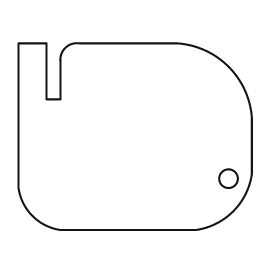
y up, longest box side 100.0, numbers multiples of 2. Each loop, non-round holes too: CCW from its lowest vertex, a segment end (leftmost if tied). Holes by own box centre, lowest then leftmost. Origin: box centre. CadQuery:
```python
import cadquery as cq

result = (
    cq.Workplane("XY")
    .moveTo(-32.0, -40.0)
    .lineTo(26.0, -40.0)
    .threePointArc((42.0, -32.0), (50.0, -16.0))
    .lineTo(50.0, 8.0)
    .threePointArc((40.0, 30.0), (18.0, 40.0))
    .lineTo(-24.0, 40.0)
    .threePointArc((-30.0, 38.0), (-32.0, 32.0))
    .lineTo(-32.0, 16.0)
    .lineTo(-38.0, 16.0)
    .lineTo(-38.0, 40.0)
    .lineTo(-50.0, 40.0)
    .lineTo(-50.0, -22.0)
    .threePointArc((-44.0, -34.0), (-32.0, -40.0))
    .close()
    .moveTo(40.0, -18.0)
    .circle(4.0)
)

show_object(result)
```